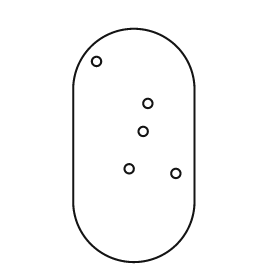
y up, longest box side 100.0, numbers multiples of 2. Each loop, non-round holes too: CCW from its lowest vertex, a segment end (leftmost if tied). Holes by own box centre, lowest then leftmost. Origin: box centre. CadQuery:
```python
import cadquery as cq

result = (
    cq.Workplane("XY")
    .moveTo(-26.0, -24.0)
    .threePointArc((0.0, -50.0), (26.0, -24.0))
    .lineTo(26.0, 24.0)
    .threePointArc((0.0, 50.0), (-26.0, 24.0))
    .close()
    .moveTo(18.0, -12.0)
    .circle(2.0)
    .moveTo(-2.0, -10.0)
    .circle(2.0)
    .moveTo(4.0, 6.0)
    .circle(2.0)
    .moveTo(6.0, 18.0)
    .circle(2.0)
    .moveTo(-16.0, 36.0)
    .circle(2.0)
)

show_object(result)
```